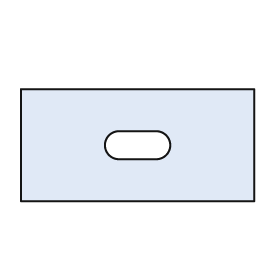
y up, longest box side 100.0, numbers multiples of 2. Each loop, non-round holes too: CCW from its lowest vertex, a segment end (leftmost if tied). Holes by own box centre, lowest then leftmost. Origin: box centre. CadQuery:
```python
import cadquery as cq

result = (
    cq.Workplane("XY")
    .moveTo(-50.0, -24.0)
    .lineTo(50.0, -24.0)
    .lineTo(50.0, 24.0)
    .lineTo(-50.0, 24.0)
    .close()
    .moveTo(-8.0, -6.0)
    .lineTo(8.0, -6.0)
    .threePointArc((14.0, 0.0), (8.0, 6.0))
    .lineTo(-8.0, 6.0)
    .threePointArc((-14.0, 0.0), (-8.0, -6.0))
    .close()
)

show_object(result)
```